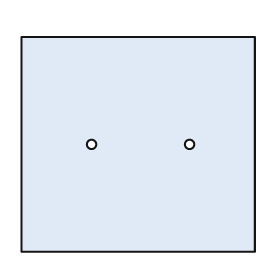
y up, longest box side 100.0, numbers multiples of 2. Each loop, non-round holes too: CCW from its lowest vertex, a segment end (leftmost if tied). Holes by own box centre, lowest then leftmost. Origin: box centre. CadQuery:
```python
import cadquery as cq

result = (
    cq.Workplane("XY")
    .moveTo(-50.0, -46.0)
    .lineTo(50.0, -46.0)
    .lineTo(50.0, 46.0)
    .lineTo(-50.0, 46.0)
    .close()
    .moveTo(-20.0, 0.0)
    .circle(2.0)
    .moveTo(22.0, 0.0)
    .circle(2.0)
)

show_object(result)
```